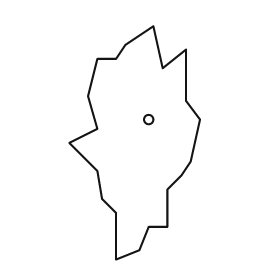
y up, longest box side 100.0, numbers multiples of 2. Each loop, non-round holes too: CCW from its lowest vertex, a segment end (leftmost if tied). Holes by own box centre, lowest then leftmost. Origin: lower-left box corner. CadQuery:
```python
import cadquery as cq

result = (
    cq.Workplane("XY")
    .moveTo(20.0, 0.0)
    .lineTo(30.0, 4.0)
    .lineTo(34.0, 14.0)
    .lineTo(42.0, 14.0)
    .lineTo(42.0, 30.0)
    .lineTo(48.0, 36.0)
    .lineTo(52.0, 42.0)
    .lineTo(56.0, 60.0)
    .lineTo(50.0, 68.0)
    .lineTo(50.0, 90.0)
    .lineTo(40.0, 82.0)
    .lineTo(36.0, 100.0)
    .lineTo(24.0, 92.0)
    .lineTo(20.0, 86.0)
    .lineTo(12.0, 86.0)
    .lineTo(8.0, 70.0)
    .lineTo(12.0, 56.0)
    .lineTo(0.0, 50.0)
    .lineTo(12.0, 38.0)
    .lineTo(14.0, 26.0)
    .lineTo(20.0, 20.0)
    .close()
    .moveTo(34.0, 60.0)
    .circle(2.0)
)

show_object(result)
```